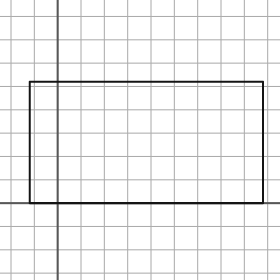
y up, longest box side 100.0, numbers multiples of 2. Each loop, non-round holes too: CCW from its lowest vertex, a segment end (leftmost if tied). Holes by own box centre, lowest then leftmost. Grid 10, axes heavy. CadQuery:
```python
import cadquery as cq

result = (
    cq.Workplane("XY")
    .moveTo(-12.0, 0.0)
    .lineTo(88.0, 0.0)
    .lineTo(88.0, 52.0)
    .lineTo(-12.0, 52.0)
    .close()
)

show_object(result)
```